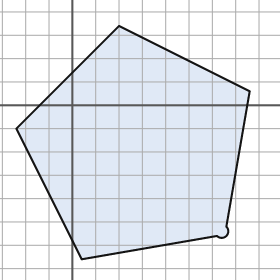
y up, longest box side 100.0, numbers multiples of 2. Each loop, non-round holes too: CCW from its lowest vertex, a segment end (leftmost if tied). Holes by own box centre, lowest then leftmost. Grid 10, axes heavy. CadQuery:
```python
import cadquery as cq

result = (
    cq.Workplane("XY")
    .moveTo(4.0, -66.0)
    .lineTo(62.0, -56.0)
    .threePointArc((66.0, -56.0), (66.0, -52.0))
    .lineTo(76.0, 6.0)
    .lineTo(20.0, 34.0)
    .lineTo(-24.0, -10.0)
    .close()
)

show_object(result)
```